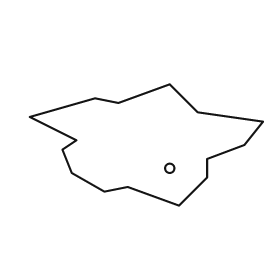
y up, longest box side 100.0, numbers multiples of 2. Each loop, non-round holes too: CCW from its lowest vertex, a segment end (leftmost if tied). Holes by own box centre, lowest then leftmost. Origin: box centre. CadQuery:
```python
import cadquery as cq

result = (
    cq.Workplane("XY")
    .moveTo(14.0, -26.0)
    .lineTo(26.0, -14.0)
    .lineTo(26.0, -6.0)
    .lineTo(42.0, 0.0)
    .lineTo(50.0, 10.0)
    .lineTo(22.0, 14.0)
    .lineTo(10.0, 26.0)
    .lineTo(-12.0, 18.0)
    .lineTo(-22.0, 20.0)
    .lineTo(-50.0, 12.0)
    .lineTo(-30.0, 2.0)
    .lineTo(-36.0, -2.0)
    .lineTo(-32.0, -12.0)
    .lineTo(-18.0, -20.0)
    .lineTo(-8.0, -18.0)
    .close()
    .moveTo(10.0, -10.0)
    .circle(2.0)
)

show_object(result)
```